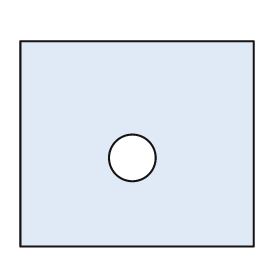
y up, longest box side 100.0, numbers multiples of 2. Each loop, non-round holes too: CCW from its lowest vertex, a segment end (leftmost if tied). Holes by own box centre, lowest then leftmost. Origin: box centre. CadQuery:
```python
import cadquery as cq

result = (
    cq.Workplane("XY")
    .moveTo(-50.0, -44.0)
    .lineTo(50.0, -44.0)
    .lineTo(50.0, 44.0)
    .lineTo(-50.0, 44.0)
    .close()
    .moveTo(-2.0, -6.0)
    .circle(10.0)
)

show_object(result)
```